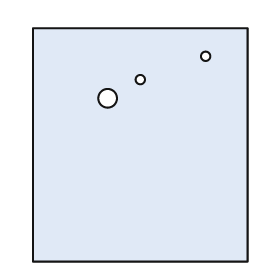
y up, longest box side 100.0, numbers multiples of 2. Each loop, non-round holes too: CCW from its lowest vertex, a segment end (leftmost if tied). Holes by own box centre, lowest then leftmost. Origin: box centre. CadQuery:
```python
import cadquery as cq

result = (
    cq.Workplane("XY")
    .moveTo(-46.0, -50.0)
    .lineTo(46.0, -50.0)
    .lineTo(46.0, 50.0)
    .lineTo(-46.0, 50.0)
    .close()
    .moveTo(-14.0, 20.0)
    .circle(4.0)
    .moveTo(0.0, 28.0)
    .circle(2.0)
    .moveTo(28.0, 38.0)
    .circle(2.0)
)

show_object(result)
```